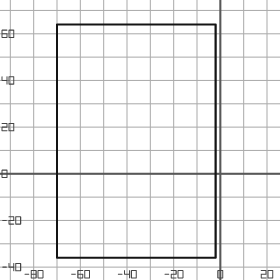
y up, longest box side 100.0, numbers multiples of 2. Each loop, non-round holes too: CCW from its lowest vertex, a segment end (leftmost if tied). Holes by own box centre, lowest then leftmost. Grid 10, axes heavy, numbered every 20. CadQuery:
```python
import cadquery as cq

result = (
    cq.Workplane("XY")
    .moveTo(-70.0, -36.0)
    .lineTo(-2.0, -36.0)
    .lineTo(-2.0, 64.0)
    .lineTo(-70.0, 64.0)
    .close()
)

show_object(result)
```